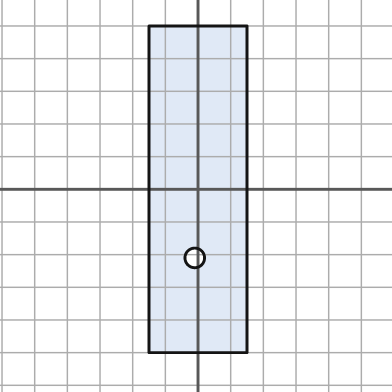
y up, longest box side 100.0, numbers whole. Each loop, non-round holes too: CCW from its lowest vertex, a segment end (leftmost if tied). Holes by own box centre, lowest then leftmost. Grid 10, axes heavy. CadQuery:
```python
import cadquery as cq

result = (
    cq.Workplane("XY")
    .moveTo(-15.0, -50.0)
    .lineTo(15.0, -50.0)
    .lineTo(15.0, 50.0)
    .lineTo(-15.0, 50.0)
    .close()
    .moveTo(-1.0, -21.0)
    .circle(3.0)
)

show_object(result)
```